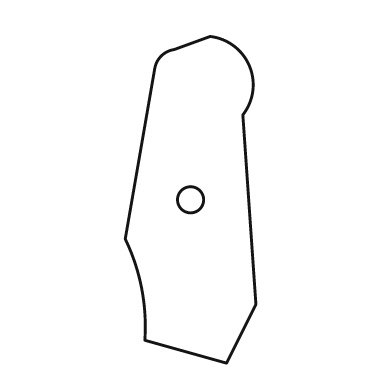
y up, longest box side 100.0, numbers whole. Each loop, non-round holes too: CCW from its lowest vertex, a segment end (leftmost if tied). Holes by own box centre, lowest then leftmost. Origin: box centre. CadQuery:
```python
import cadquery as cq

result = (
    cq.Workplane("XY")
    .moveTo(11.0, -50.0)
    .lineTo(20.0, -32.0)
    .lineTo(16.0, 26.0)
    .threePointArc((18.0, 41.0), (6.0, 50.0))
    .lineTo(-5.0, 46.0)
    .threePointArc((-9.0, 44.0), (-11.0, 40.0))
    .lineTo(-20.0, -12.0)
    .threePointArc((-15.0, -27.0), (-14.0, -43.0))
    .close()
    .moveTo(0.0, 0.0)
    .circle(4.0)
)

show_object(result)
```